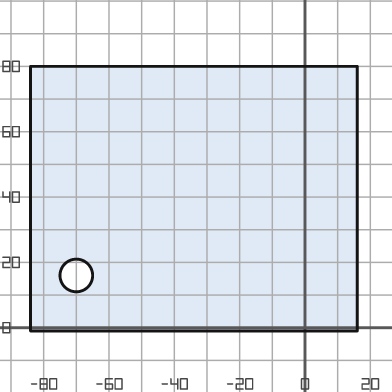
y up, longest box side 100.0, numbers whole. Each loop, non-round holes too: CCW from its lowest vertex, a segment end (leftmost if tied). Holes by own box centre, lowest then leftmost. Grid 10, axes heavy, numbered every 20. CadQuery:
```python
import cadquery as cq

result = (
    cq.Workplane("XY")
    .moveTo(-84.0, -1.0)
    .lineTo(16.0, -1.0)
    .lineTo(16.0, 80.0)
    .lineTo(-84.0, 80.0)
    .close()
    .moveTo(-70.0, 16.0)
    .circle(5.0)
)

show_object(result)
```